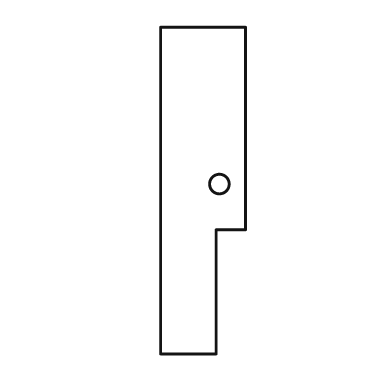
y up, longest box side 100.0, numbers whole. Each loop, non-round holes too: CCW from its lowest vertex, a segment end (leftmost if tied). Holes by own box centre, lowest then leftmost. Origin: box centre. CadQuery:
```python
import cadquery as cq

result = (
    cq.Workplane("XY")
    .moveTo(-13.0, -50.0)
    .lineTo(4.0, -50.0)
    .lineTo(4.0, -12.0)
    .lineTo(13.0, -12.0)
    .lineTo(13.0, 50.0)
    .lineTo(-13.0, 50.0)
    .close()
    .moveTo(5.0, 2.0)
    .circle(3.0)
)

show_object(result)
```